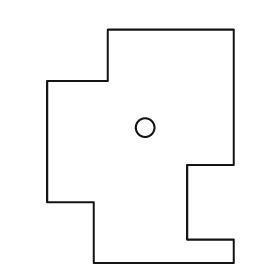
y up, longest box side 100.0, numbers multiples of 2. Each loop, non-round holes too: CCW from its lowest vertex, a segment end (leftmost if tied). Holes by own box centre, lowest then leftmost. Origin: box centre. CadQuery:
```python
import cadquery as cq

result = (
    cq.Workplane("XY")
    .moveTo(-20.0, -50.0)
    .lineTo(40.0, -50.0)
    .lineTo(40.0, -40.0)
    .lineTo(20.0, -40.0)
    .lineTo(20.0, -8.0)
    .lineTo(40.0, -8.0)
    .lineTo(40.0, 50.0)
    .lineTo(-14.0, 50.0)
    .lineTo(-14.0, 28.0)
    .lineTo(-40.0, 28.0)
    .lineTo(-40.0, -24.0)
    .lineTo(-20.0, -24.0)
    .close()
    .moveTo(2.0, 8.0)
    .circle(4.0)
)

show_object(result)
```